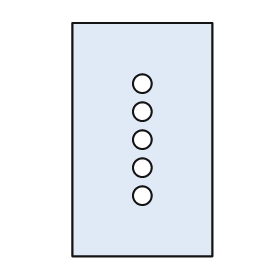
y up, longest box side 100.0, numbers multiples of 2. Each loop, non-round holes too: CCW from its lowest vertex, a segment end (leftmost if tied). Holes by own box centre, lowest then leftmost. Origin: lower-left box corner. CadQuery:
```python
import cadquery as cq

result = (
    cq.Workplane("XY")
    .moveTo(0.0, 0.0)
    .lineTo(60.0, 0.0)
    .lineTo(60.0, 100.0)
    .lineTo(0.0, 100.0)
    .close()
    .moveTo(30.0, 26.0)
    .circle(4.0)
    .moveTo(30.0, 38.0)
    .circle(4.0)
    .moveTo(30.0, 50.0)
    .circle(4.0)
    .moveTo(30.0, 62.0)
    .circle(4.0)
    .moveTo(30.0, 74.0)
    .circle(4.0)
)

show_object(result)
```